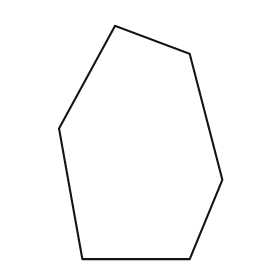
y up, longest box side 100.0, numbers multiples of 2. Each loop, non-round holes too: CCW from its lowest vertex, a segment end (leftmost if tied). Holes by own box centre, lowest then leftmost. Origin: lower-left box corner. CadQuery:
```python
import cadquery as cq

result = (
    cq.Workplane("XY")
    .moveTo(10.0, 0.0)
    .lineTo(56.0, 0.0)
    .lineTo(70.0, 34.0)
    .lineTo(56.0, 88.0)
    .lineTo(24.0, 100.0)
    .lineTo(0.0, 56.0)
    .close()
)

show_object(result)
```